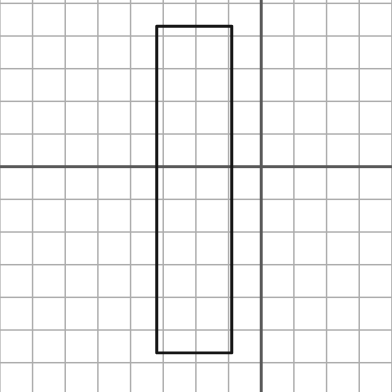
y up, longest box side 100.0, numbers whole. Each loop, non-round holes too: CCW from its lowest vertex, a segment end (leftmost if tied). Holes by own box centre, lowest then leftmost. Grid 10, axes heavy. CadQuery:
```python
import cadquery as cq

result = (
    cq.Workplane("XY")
    .moveTo(-32.0, -57.0)
    .lineTo(-9.0, -57.0)
    .lineTo(-9.0, 43.0)
    .lineTo(-32.0, 43.0)
    .close()
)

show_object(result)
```